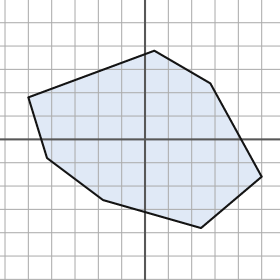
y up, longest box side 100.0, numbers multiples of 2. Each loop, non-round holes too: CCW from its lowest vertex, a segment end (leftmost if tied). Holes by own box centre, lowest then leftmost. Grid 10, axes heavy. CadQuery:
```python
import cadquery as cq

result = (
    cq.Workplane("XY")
    .moveTo(24.0, -38.0)
    .lineTo(50.0, -16.0)
    .lineTo(28.0, 24.0)
    .lineTo(4.0, 38.0)
    .lineTo(-50.0, 18.0)
    .lineTo(-42.0, -8.0)
    .lineTo(-18.0, -26.0)
    .close()
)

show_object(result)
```